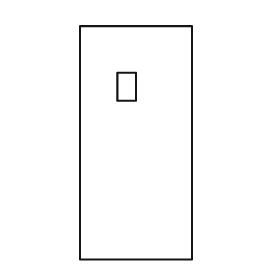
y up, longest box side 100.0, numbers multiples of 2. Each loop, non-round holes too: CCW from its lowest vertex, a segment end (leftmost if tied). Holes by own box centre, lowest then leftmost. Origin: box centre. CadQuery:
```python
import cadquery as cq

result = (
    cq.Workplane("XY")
    .moveTo(-24.0, -50.0)
    .lineTo(24.0, -50.0)
    .lineTo(24.0, 50.0)
    .lineTo(-24.0, 50.0)
    .close()
    .moveTo(-8.0, 18.0)
    .lineTo(0.0, 18.0)
    .lineTo(0.0, 30.0)
    .lineTo(-8.0, 30.0)
    .close()
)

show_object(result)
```